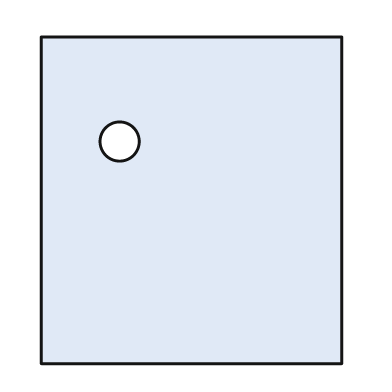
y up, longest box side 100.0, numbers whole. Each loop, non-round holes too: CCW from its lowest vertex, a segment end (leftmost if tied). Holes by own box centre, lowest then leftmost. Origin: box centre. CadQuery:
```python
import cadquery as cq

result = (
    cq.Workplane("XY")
    .moveTo(-46.0, -50.0)
    .lineTo(46.0, -50.0)
    .lineTo(46.0, 50.0)
    .lineTo(-46.0, 50.0)
    .close()
    .moveTo(-22.0, 18.0)
    .circle(6.0)
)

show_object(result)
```